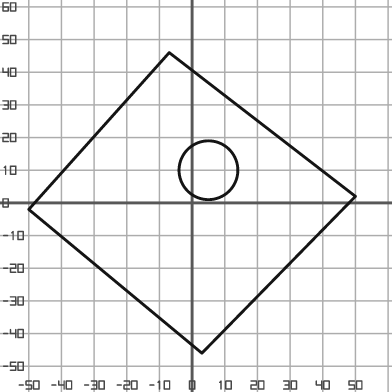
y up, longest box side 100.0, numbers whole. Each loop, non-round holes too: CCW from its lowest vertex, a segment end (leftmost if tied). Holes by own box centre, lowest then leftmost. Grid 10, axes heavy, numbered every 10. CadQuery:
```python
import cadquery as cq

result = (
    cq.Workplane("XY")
    .moveTo(3.0, -46.0)
    .lineTo(50.0, 2.0)
    .lineTo(-7.0, 46.0)
    .lineTo(-50.0, -2.0)
    .close()
    .moveTo(5.0, 10.0)
    .circle(9.0)
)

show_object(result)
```